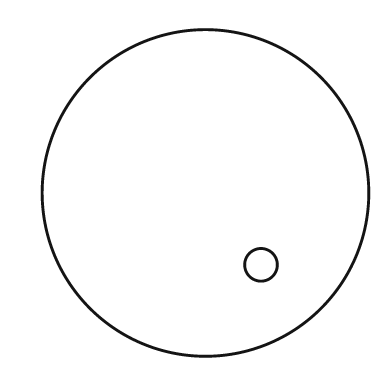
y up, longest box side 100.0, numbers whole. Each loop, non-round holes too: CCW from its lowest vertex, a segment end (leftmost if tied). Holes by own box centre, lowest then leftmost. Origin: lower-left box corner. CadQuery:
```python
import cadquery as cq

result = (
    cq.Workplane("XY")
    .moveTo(50.0, 50.0)
    .circle(50.0)
    .moveTo(67.0, 28.0)
    .circle(5.0)
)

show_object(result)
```